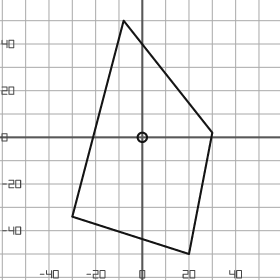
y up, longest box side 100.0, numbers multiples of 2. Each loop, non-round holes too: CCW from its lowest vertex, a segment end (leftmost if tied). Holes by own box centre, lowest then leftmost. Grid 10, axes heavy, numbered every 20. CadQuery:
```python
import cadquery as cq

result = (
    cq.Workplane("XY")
    .moveTo(20.0, -50.0)
    .lineTo(30.0, 2.0)
    .lineTo(-8.0, 50.0)
    .lineTo(-30.0, -34.0)
    .close()
    .moveTo(0.0, 0.0)
    .circle(2.0)
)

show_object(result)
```